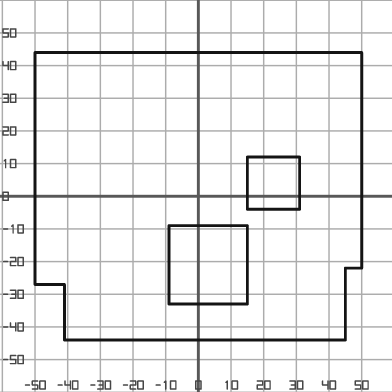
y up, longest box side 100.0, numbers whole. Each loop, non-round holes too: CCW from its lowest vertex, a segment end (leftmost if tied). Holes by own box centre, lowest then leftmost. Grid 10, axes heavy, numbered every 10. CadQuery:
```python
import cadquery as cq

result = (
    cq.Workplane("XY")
    .moveTo(-41.0, -44.0)
    .lineTo(45.0, -44.0)
    .lineTo(45.0, -22.0)
    .lineTo(50.0, -22.0)
    .lineTo(50.0, 44.0)
    .lineTo(-50.0, 44.0)
    .lineTo(-50.0, -27.0)
    .lineTo(-41.0, -27.0)
    .close()
    .moveTo(-9.0, -33.0)
    .lineTo(15.0, -33.0)
    .lineTo(15.0, -9.0)
    .lineTo(-9.0, -9.0)
    .close()
    .moveTo(15.0, -4.0)
    .lineTo(31.0, -4.0)
    .lineTo(31.0, 12.0)
    .lineTo(15.0, 12.0)
    .close()
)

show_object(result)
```